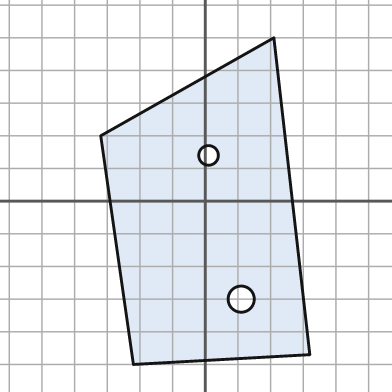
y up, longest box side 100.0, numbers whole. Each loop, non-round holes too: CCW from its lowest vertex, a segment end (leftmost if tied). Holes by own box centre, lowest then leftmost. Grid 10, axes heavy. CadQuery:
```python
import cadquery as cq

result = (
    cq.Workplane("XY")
    .moveTo(-22.0, -50.0)
    .lineTo(32.0, -47.0)
    .lineTo(21.0, 50.0)
    .lineTo(-32.0, 20.0)
    .close()
    .moveTo(11.0, -30.0)
    .circle(4.0)
    .moveTo(1.0, 14.0)
    .circle(3.0)
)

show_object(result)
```